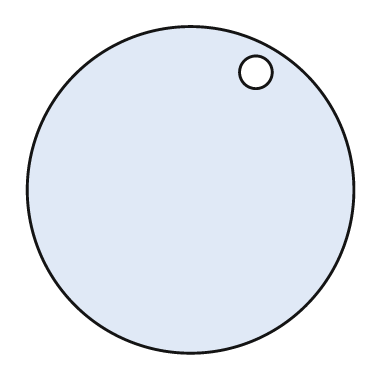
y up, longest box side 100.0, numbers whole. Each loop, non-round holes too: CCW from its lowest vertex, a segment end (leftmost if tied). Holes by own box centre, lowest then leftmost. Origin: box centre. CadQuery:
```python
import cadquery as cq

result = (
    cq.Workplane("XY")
    .moveTo(0.0, 0.0)
    .circle(50.0)
    .moveTo(20.0, 36.0)
    .circle(5.0)
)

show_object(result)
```